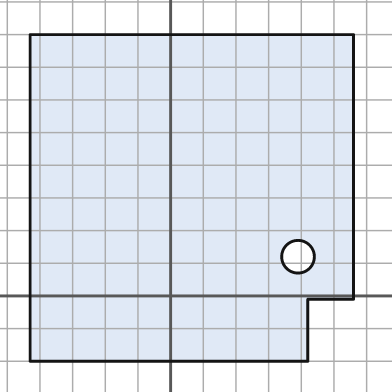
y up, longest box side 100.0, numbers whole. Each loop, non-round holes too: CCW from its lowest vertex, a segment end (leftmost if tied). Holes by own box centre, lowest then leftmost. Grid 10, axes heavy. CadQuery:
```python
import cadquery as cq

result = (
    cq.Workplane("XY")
    .moveTo(-43.0, -20.0)
    .lineTo(42.0, -20.0)
    .lineTo(42.0, -1.0)
    .lineTo(56.0, -1.0)
    .lineTo(56.0, 80.0)
    .lineTo(-43.0, 80.0)
    .close()
    .moveTo(39.0, 12.0)
    .circle(5.0)
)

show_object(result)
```